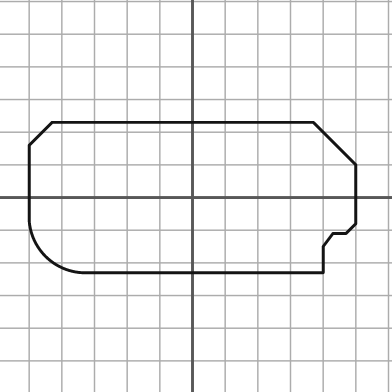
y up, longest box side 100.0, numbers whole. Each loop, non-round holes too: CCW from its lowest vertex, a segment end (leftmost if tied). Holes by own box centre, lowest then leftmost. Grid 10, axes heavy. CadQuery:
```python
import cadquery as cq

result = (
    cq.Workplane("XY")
    .moveTo(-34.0, -23.0)
    .lineTo(40.0, -23.0)
    .lineTo(40.0, -15.0)
    .lineTo(43.0, -11.0)
    .lineTo(47.0, -11.0)
    .lineTo(50.0, -8.0)
    .lineTo(50.0, 10.0)
    .lineTo(37.0, 23.0)
    .lineTo(-43.0, 23.0)
    .lineTo(-50.0, 16.0)
    .lineTo(-50.0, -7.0)
    .threePointArc((-45.0, -18.0), (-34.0, -23.0))
    .close()
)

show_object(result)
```